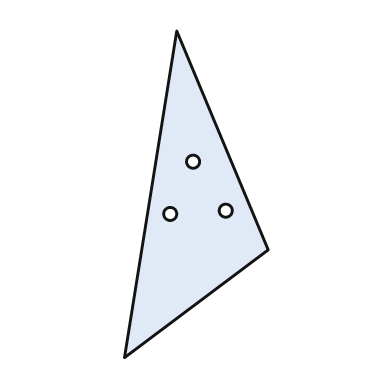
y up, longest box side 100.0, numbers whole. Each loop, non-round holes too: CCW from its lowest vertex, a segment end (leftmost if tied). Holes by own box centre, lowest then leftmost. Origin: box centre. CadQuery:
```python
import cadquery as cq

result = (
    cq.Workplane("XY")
    .moveTo(-22.0, -50.0)
    .lineTo(22.0, -17.0)
    .lineTo(-6.0, 50.0)
    .close()
    .moveTo(-8.0, -6.0)
    .circle(2.0)
    .moveTo(9.0, -5.0)
    .circle(2.0)
    .moveTo(-1.0, 10.0)
    .circle(2.0)
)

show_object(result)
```